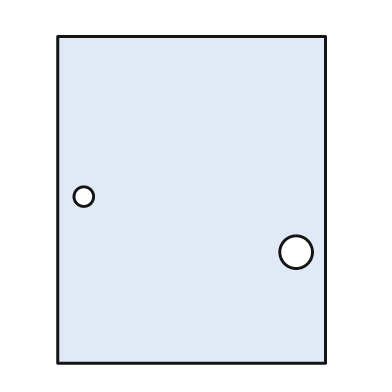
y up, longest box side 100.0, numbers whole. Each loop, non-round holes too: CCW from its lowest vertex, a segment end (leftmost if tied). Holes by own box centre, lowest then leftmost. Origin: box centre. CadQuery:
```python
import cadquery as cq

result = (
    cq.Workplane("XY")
    .moveTo(-41.0, -50.0)
    .lineTo(41.0, -50.0)
    .lineTo(41.0, 50.0)
    .lineTo(-41.0, 50.0)
    .close()
    .moveTo(32.0, -16.0)
    .circle(5.0)
    .moveTo(-33.0, 1.0)
    .circle(3.0)
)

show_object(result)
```